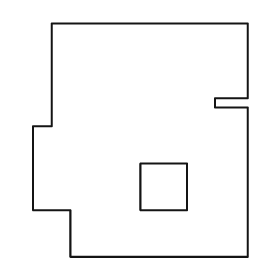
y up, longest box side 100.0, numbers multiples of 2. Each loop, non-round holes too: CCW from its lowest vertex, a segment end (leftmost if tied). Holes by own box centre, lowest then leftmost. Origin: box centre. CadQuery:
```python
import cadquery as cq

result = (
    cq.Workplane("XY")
    .moveTo(-30.0, -50.0)
    .lineTo(46.0, -50.0)
    .lineTo(46.0, 14.0)
    .lineTo(32.0, 14.0)
    .lineTo(32.0, 18.0)
    .lineTo(46.0, 18.0)
    .lineTo(46.0, 50.0)
    .lineTo(-38.0, 50.0)
    .lineTo(-38.0, 6.0)
    .lineTo(-46.0, 6.0)
    .lineTo(-46.0, -30.0)
    .lineTo(-30.0, -30.0)
    .close()
    .moveTo(0.0, -30.0)
    .lineTo(20.0, -30.0)
    .lineTo(20.0, -10.0)
    .lineTo(0.0, -10.0)
    .close()
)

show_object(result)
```